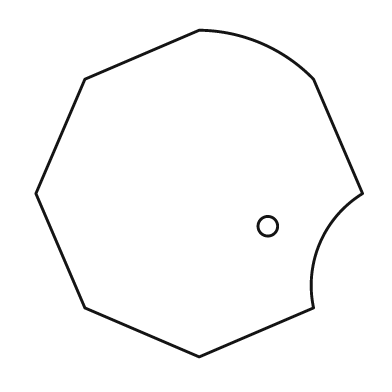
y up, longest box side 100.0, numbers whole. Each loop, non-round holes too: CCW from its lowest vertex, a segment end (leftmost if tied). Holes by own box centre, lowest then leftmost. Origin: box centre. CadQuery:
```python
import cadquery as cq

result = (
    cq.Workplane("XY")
    .moveTo(0.0, -50.0)
    .lineTo(35.0, -35.0)
    .threePointArc((37.0, -15.0), (50.0, 0.0))
    .lineTo(35.0, 35.0)
    .threePointArc((19.0, 46.0), (0.0, 50.0))
    .lineTo(-35.0, 35.0)
    .lineTo(-50.0, 0.0)
    .lineTo(-35.0, -35.0)
    .close()
    .moveTo(21.0, -10.0)
    .circle(3.0)
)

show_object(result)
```